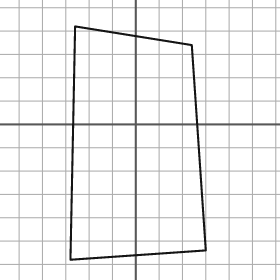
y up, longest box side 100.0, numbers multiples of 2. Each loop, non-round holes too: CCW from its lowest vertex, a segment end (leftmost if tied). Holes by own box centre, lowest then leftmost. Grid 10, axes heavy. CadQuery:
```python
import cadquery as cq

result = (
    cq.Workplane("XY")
    .moveTo(-28.0, -58.0)
    .lineTo(30.0, -54.0)
    .lineTo(24.0, 34.0)
    .lineTo(-26.0, 42.0)
    .close()
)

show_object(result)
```